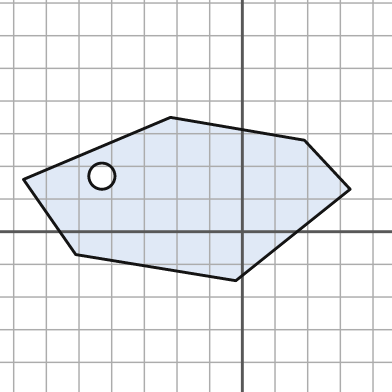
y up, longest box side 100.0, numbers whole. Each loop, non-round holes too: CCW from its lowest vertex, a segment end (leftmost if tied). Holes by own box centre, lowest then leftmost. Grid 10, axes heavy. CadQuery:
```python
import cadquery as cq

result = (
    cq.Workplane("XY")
    .moveTo(-2.0, -15.0)
    .lineTo(33.0, 13.0)
    .lineTo(19.0, 28.0)
    .lineTo(-22.0, 35.0)
    .lineTo(-67.0, 16.0)
    .lineTo(-51.0, -7.0)
    .close()
    .moveTo(-43.0, 17.0)
    .circle(4.0)
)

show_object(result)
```